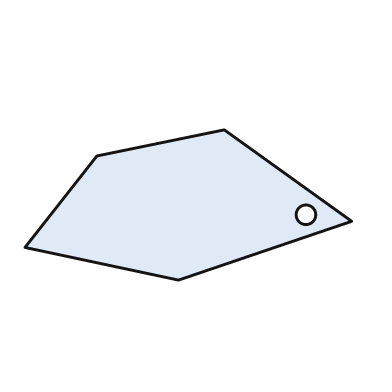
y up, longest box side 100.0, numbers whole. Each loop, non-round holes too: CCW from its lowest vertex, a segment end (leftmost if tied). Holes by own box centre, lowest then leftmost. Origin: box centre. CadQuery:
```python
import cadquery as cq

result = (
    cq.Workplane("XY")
    .moveTo(-3.0, -23.0)
    .lineTo(50.0, -5.0)
    .lineTo(11.0, 23.0)
    .lineTo(-28.0, 15.0)
    .lineTo(-50.0, -13.0)
    .close()
    .moveTo(36.0, -3.0)
    .circle(3.0)
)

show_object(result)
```